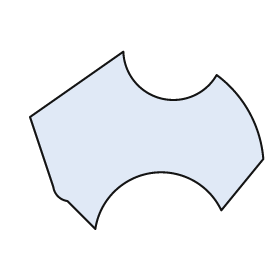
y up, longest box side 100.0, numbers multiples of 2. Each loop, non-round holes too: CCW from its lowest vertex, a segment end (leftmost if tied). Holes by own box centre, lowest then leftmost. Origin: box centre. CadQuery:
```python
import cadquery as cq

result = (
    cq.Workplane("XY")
    .moveTo(-22.0, -38.0)
    .threePointArc((2.0, -14.0), (32.0, -30.0))
    .lineTo(50.0, -8.0)
    .threePointArc((44.0, 12.0), (30.0, 28.0))
    .threePointArc((6.0, 18.0), (-10.0, 38.0))
    .lineTo(-50.0, 10.0)
    .lineTo(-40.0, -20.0)
    .threePointArc((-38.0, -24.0), (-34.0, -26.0))
    .close()
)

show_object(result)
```